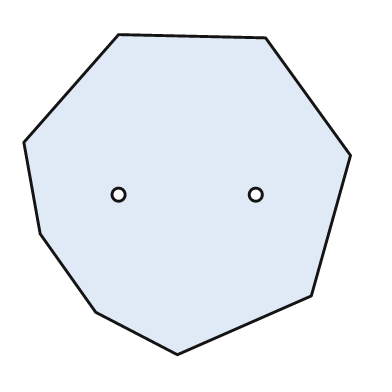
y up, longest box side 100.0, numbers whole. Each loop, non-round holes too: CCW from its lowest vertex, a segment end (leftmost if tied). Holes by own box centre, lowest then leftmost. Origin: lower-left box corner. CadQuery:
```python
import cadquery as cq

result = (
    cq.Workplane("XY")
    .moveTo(47.0, 0.0)
    .lineTo(88.0, 18.0)
    .lineTo(100.0, 61.0)
    .lineTo(74.0, 97.0)
    .lineTo(29.0, 98.0)
    .lineTo(0.0, 65.0)
    .lineTo(5.0, 37.0)
    .lineTo(22.0, 13.0)
    .close()
    .moveTo(29.0, 49.0)
    .circle(2.0)
    .moveTo(71.0, 49.0)
    .circle(2.0)
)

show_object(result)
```